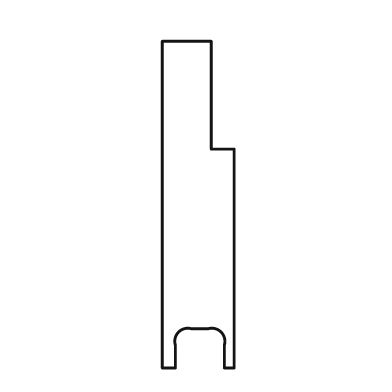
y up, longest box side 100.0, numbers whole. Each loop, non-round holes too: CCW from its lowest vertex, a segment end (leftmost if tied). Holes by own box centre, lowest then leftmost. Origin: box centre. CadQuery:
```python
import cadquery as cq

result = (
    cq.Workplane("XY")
    .moveTo(-11.0, -50.0)
    .lineTo(-7.0, -50.0)
    .lineTo(-7.0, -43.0)
    .threePointArc((-6.0, -39.0), (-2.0, -38.0))
    .lineTo(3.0, -38.0)
    .threePointArc((7.0, -39.0), (8.0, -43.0))
    .lineTo(8.0, -50.0)
    .lineTo(11.0, -50.0)
    .lineTo(11.0, 17.0)
    .lineTo(4.0, 17.0)
    .lineTo(4.0, 50.0)
    .lineTo(-11.0, 50.0)
    .close()
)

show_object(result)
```